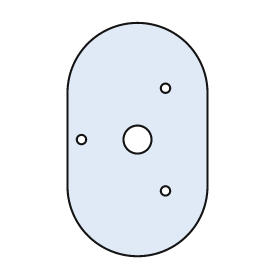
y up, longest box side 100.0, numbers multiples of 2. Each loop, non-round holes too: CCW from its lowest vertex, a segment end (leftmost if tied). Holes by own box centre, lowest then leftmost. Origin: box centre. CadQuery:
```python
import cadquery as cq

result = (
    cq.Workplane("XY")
    .moveTo(-30.0, -20.0)
    .threePointArc((0.0, -50.0), (30.0, -20.0))
    .lineTo(30.0, 20.0)
    .threePointArc((0.0, 50.0), (-30.0, 20.0))
    .close()
    .moveTo(12.0, -22.0)
    .circle(2.0)
    .moveTo(-24.0, 0.0)
    .circle(2.0)
    .moveTo(0.0, 0.0)
    .circle(6.0)
    .moveTo(12.0, 22.0)
    .circle(2.0)
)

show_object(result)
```